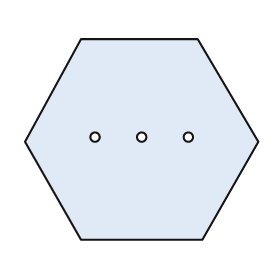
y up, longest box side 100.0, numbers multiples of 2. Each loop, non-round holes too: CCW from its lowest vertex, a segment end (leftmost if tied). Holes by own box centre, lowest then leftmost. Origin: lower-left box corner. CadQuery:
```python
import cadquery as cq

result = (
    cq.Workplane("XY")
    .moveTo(24.0, 0.0)
    .lineTo(76.0, 0.0)
    .lineTo(100.0, 42.0)
    .lineTo(74.0, 86.0)
    .lineTo(24.0, 86.0)
    .lineTo(0.0, 42.0)
    .close()
    .moveTo(30.0, 44.0)
    .circle(2.0)
    .moveTo(50.0, 44.0)
    .circle(2.0)
    .moveTo(70.0, 44.0)
    .circle(2.0)
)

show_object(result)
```